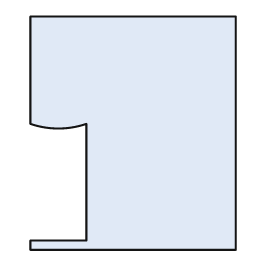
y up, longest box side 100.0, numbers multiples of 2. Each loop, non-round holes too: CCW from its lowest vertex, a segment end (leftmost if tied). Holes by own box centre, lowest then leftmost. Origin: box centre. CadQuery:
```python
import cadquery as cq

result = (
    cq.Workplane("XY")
    .moveTo(-44.0, -50.0)
    .lineTo(44.0, -50.0)
    .lineTo(44.0, 50.0)
    .lineTo(-44.0, 50.0)
    .lineTo(-44.0, 4.0)
    .threePointArc((-32.0, 2.0), (-20.0, 4.0))
    .lineTo(-20.0, -46.0)
    .lineTo(-44.0, -46.0)
    .close()
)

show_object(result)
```